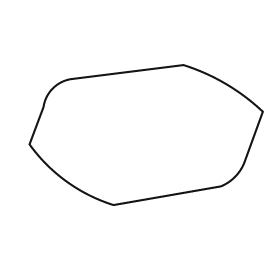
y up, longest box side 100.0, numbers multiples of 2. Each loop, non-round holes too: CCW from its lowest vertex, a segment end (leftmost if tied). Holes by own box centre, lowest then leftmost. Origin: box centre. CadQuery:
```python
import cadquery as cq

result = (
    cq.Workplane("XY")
    .moveTo(-14.0, -30.0)
    .lineTo(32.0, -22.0)
    .threePointArc((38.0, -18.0), (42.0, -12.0))
    .lineTo(50.0, 10.0)
    .threePointArc((34.0, 22.0), (16.0, 30.0))
    .lineTo(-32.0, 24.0)
    .threePointArc((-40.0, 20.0), (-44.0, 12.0))
    .lineTo(-50.0, -4.0)
    .threePointArc((-34.0, -20.0), (-14.0, -30.0))
    .close()
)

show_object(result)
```